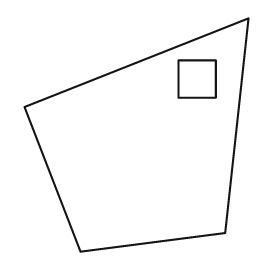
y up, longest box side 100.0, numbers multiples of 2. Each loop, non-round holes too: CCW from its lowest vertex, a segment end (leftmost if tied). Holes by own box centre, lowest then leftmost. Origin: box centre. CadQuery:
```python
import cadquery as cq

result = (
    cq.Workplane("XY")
    .moveTo(-24.0, -50.0)
    .lineTo(38.0, -42.0)
    .lineTo(48.0, 50.0)
    .lineTo(-48.0, 12.0)
    .close()
    .moveTo(18.0, 16.0)
    .lineTo(34.0, 16.0)
    .lineTo(34.0, 32.0)
    .lineTo(18.0, 32.0)
    .close()
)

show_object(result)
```